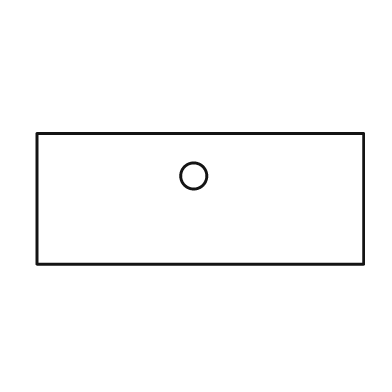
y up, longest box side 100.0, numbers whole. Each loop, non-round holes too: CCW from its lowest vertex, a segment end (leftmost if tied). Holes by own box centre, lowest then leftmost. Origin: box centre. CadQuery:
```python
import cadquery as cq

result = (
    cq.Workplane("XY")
    .moveTo(-50.0, -20.0)
    .lineTo(50.0, -20.0)
    .lineTo(50.0, 20.0)
    .lineTo(-50.0, 20.0)
    .close()
    .moveTo(-2.0, 7.0)
    .circle(4.0)
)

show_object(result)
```